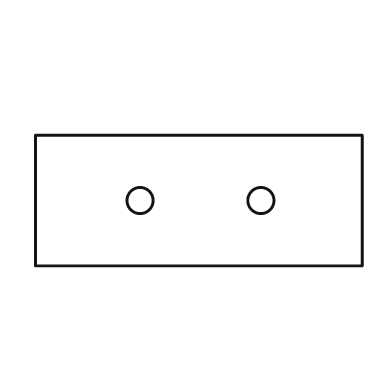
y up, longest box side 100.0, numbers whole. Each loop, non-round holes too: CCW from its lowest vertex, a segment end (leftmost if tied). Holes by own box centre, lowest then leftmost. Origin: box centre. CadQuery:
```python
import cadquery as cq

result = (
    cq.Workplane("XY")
    .moveTo(-50.0, -20.0)
    .lineTo(50.0, -20.0)
    .lineTo(50.0, 20.0)
    .lineTo(-50.0, 20.0)
    .close()
    .moveTo(-18.0, 0.0)
    .circle(4.0)
    .moveTo(19.0, 0.0)
    .circle(4.0)
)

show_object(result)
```